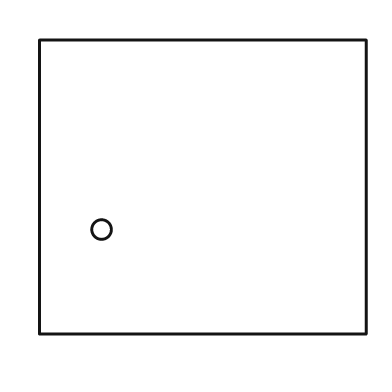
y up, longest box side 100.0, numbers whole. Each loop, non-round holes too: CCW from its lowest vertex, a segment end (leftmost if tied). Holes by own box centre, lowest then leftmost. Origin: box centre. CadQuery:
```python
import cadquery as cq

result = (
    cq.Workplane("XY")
    .moveTo(-50.0, -45.0)
    .lineTo(50.0, -45.0)
    .lineTo(50.0, 45.0)
    .lineTo(-50.0, 45.0)
    .close()
    .moveTo(-31.0, -13.0)
    .circle(3.0)
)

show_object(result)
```